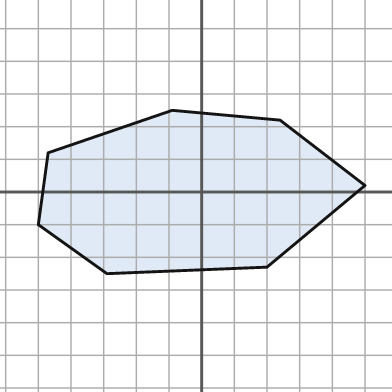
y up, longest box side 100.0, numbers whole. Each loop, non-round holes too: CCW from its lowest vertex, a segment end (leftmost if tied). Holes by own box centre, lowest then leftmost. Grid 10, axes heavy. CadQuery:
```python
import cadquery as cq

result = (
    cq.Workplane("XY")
    .moveTo(-29.0, -25.0)
    .lineTo(20.0, -23.0)
    .lineTo(50.0, 2.0)
    .lineTo(24.0, 22.0)
    .lineTo(-9.0, 25.0)
    .lineTo(-47.0, 12.0)
    .lineTo(-50.0, -10.0)
    .close()
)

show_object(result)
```